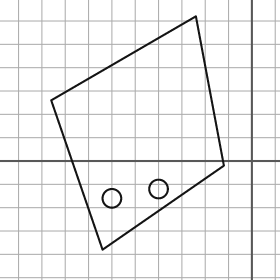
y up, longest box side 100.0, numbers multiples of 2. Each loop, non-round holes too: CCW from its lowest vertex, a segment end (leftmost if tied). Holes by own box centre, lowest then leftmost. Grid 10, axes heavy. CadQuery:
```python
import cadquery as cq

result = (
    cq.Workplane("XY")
    .moveTo(-64.0, -38.0)
    .lineTo(-12.0, -2.0)
    .lineTo(-24.0, 62.0)
    .lineTo(-86.0, 26.0)
    .close()
    .moveTo(-60.0, -16.0)
    .circle(4.0)
    .moveTo(-40.0, -12.0)
    .circle(4.0)
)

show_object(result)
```